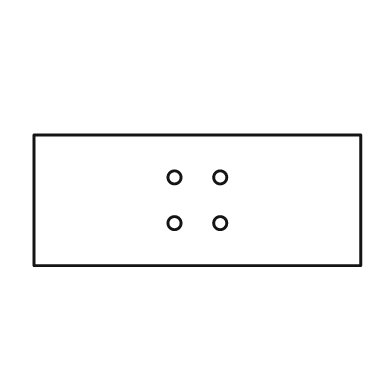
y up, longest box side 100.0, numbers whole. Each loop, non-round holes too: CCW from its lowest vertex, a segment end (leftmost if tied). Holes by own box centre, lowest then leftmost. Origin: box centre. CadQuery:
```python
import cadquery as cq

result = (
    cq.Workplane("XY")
    .moveTo(-50.0, -20.0)
    .lineTo(50.0, -20.0)
    .lineTo(50.0, 20.0)
    .lineTo(-50.0, 20.0)
    .close()
    .moveTo(-7.0, -7.0)
    .circle(2.0)
    .moveTo(7.0, -7.0)
    .circle(2.0)
    .moveTo(-7.0, 7.0)
    .circle(2.0)
    .moveTo(7.0, 7.0)
    .circle(2.0)
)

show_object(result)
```